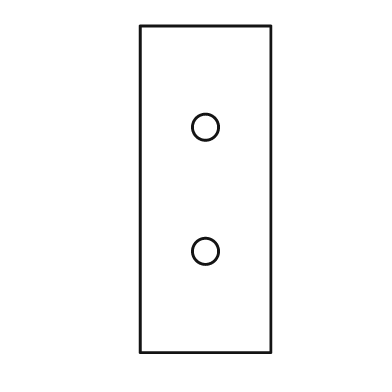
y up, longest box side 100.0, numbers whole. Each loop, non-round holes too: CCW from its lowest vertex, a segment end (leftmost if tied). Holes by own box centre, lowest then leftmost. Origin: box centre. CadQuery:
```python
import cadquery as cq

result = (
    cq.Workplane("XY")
    .moveTo(-20.0, -50.0)
    .lineTo(20.0, -50.0)
    .lineTo(20.0, 50.0)
    .lineTo(-20.0, 50.0)
    .close()
    .moveTo(0.0, -19.0)
    .circle(4.0)
    .moveTo(0.0, 19.0)
    .circle(4.0)
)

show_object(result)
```